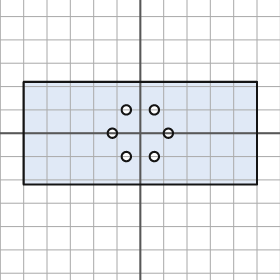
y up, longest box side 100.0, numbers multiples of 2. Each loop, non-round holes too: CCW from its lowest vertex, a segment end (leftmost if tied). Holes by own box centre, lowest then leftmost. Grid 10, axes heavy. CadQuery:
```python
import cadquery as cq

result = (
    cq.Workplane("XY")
    .moveTo(-50.0, -22.0)
    .lineTo(50.0, -22.0)
    .lineTo(50.0, 22.0)
    .lineTo(-50.0, 22.0)
    .close()
    .moveTo(-6.0, -10.0)
    .circle(2.0)
    .moveTo(6.0, -10.0)
    .circle(2.0)
    .moveTo(-12.0, 0.0)
    .circle(2.0)
    .moveTo(12.0, 0.0)
    .circle(2.0)
    .moveTo(-6.0, 10.0)
    .circle(2.0)
    .moveTo(6.0, 10.0)
    .circle(2.0)
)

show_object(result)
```